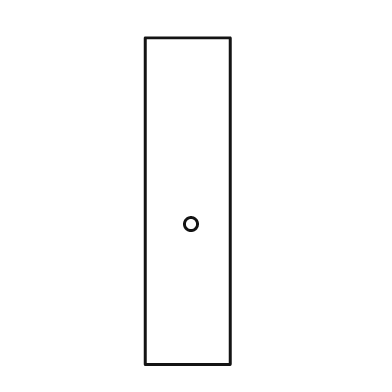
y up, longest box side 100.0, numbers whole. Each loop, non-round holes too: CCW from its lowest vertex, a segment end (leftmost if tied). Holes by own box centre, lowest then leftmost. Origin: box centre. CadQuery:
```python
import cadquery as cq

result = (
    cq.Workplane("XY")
    .moveTo(-13.0, -50.0)
    .lineTo(13.0, -50.0)
    .lineTo(13.0, 50.0)
    .lineTo(-13.0, 50.0)
    .close()
    .moveTo(1.0, -7.0)
    .circle(2.0)
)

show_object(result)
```